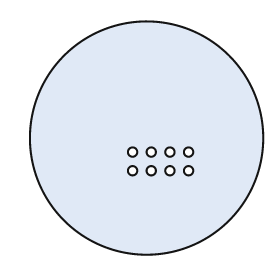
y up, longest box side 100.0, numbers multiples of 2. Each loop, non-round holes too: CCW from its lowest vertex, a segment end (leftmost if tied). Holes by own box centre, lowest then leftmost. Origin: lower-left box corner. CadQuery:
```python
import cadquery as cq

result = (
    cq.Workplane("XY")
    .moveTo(50.0, 50.0)
    .circle(50.0)
    .moveTo(44.0, 36.0)
    .circle(2.0)
    .moveTo(52.0, 36.0)
    .circle(2.0)
    .moveTo(60.0, 36.0)
    .circle(2.0)
    .moveTo(68.0, 36.0)
    .circle(2.0)
    .moveTo(44.0, 44.0)
    .circle(2.0)
    .moveTo(52.0, 44.0)
    .circle(2.0)
    .moveTo(60.0, 44.0)
    .circle(2.0)
    .moveTo(68.0, 44.0)
    .circle(2.0)
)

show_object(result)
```